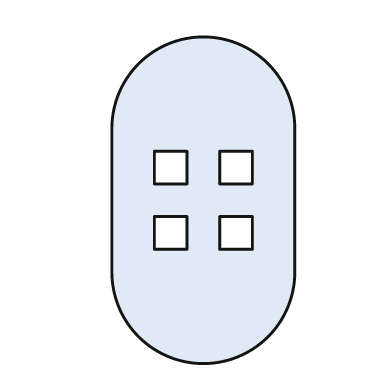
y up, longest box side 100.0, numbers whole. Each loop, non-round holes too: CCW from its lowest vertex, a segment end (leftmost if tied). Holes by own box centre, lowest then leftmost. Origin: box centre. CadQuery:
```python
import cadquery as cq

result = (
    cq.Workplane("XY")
    .moveTo(-28.0, -22.0)
    .threePointArc((0.0, -50.0), (28.0, -22.0))
    .lineTo(28.0, 22.0)
    .threePointArc((0.0, 50.0), (-28.0, 22.0))
    .close()
    .moveTo(-15.0, -15.0)
    .lineTo(-5.0, -15.0)
    .lineTo(-5.0, -5.0)
    .lineTo(-15.0, -5.0)
    .close()
    .moveTo(5.0, -15.0)
    .lineTo(15.0, -15.0)
    .lineTo(15.0, -5.0)
    .lineTo(5.0, -5.0)
    .close()
    .moveTo(-15.0, 5.0)
    .lineTo(-5.0, 5.0)
    .lineTo(-5.0, 15.0)
    .lineTo(-15.0, 15.0)
    .close()
    .moveTo(5.0, 5.0)
    .lineTo(15.0, 5.0)
    .lineTo(15.0, 15.0)
    .lineTo(5.0, 15.0)
    .close()
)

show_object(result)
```